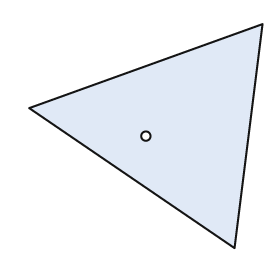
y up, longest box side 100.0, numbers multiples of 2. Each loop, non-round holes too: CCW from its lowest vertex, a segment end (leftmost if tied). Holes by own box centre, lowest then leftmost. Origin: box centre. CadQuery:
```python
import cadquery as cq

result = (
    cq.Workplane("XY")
    .moveTo(38.0, -48.0)
    .lineTo(50.0, 48.0)
    .lineTo(-50.0, 12.0)
    .close()
    .moveTo(0.0, 0.0)
    .circle(2.0)
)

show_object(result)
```